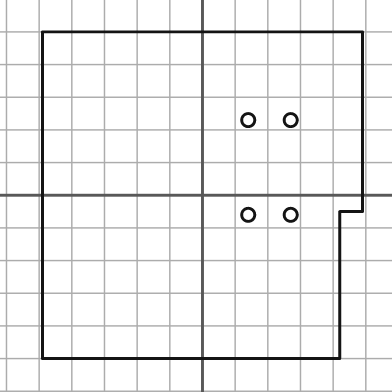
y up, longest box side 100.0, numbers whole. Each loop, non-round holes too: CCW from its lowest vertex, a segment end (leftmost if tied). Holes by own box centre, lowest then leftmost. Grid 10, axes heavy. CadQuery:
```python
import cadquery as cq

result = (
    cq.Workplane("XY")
    .moveTo(-49.0, -50.0)
    .lineTo(42.0, -50.0)
    .lineTo(42.0, -5.0)
    .lineTo(49.0, -5.0)
    .lineTo(49.0, 50.0)
    .lineTo(-49.0, 50.0)
    .close()
    .moveTo(14.0, -6.0)
    .circle(2.0)
    .moveTo(27.0, -6.0)
    .circle(2.0)
    .moveTo(14.0, 23.0)
    .circle(2.0)
    .moveTo(27.0, 23.0)
    .circle(2.0)
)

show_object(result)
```